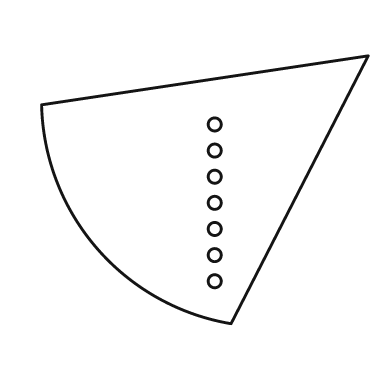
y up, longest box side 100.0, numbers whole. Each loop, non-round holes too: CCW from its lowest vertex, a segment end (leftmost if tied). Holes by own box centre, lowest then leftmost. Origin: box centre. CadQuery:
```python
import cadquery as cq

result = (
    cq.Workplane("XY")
    .moveTo(8.0, -41.0)
    .lineTo(50.0, 41.0)
    .lineTo(-50.0, 26.0)
    .threePointArc((-33.0, -18.0), (8.0, -41.0))
    .close()
    .moveTo(3.0, -28.0)
    .circle(2.0)
    .moveTo(3.0, -20.0)
    .circle(2.0)
    .moveTo(3.0, -12.0)
    .circle(2.0)
    .moveTo(3.0, -4.0)
    .circle(2.0)
    .moveTo(3.0, 4.0)
    .circle(2.0)
    .moveTo(3.0, 12.0)
    .circle(2.0)
    .moveTo(3.0, 20.0)
    .circle(2.0)
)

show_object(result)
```